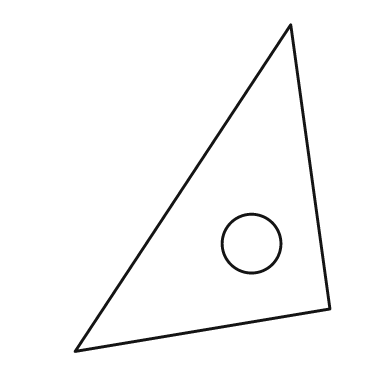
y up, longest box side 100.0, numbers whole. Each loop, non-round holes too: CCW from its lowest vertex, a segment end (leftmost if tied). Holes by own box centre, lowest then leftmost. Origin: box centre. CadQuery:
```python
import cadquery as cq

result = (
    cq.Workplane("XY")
    .moveTo(-39.0, -50.0)
    .lineTo(39.0, -37.0)
    .lineTo(27.0, 50.0)
    .close()
    .moveTo(15.0, -17.0)
    .circle(9.0)
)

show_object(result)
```